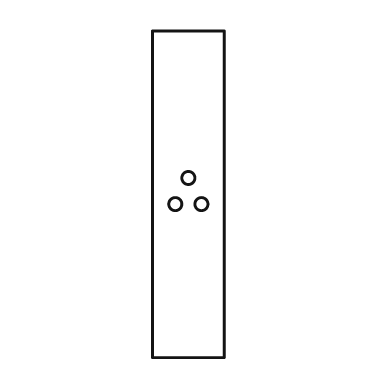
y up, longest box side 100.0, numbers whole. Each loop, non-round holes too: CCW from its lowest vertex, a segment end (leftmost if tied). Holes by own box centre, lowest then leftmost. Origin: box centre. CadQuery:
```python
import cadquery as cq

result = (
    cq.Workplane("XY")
    .moveTo(-11.0, -50.0)
    .lineTo(11.0, -50.0)
    .lineTo(11.0, 50.0)
    .lineTo(-11.0, 50.0)
    .close()
    .moveTo(-4.0, -3.0)
    .circle(2.0)
    .moveTo(4.0, -3.0)
    .circle(2.0)
    .moveTo(0.0, 5.0)
    .circle(2.0)
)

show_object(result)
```